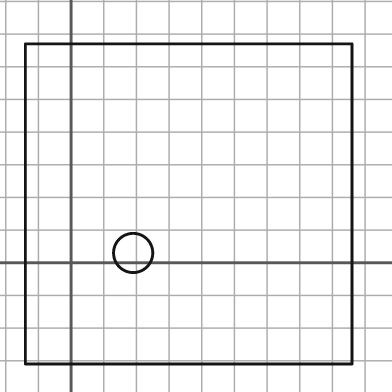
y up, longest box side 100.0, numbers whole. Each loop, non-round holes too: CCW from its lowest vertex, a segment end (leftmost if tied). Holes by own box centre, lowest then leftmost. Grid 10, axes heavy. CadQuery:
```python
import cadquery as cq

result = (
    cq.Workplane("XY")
    .moveTo(-14.0, -31.0)
    .lineTo(86.0, -31.0)
    .lineTo(86.0, 67.0)
    .lineTo(-14.0, 67.0)
    .close()
    .moveTo(19.0, 3.0)
    .circle(6.0)
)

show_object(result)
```